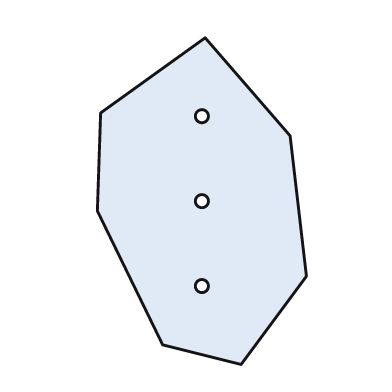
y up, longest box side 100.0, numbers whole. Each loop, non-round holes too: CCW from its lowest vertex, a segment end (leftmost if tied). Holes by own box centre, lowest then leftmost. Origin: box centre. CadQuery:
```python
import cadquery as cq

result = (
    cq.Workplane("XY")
    .moveTo(12.0, -50.0)
    .lineTo(32.0, -23.0)
    .lineTo(27.0, 20.0)
    .lineTo(1.0, 50.0)
    .lineTo(-31.0, 27.0)
    .lineTo(-32.0, -3.0)
    .lineTo(-12.0, -44.0)
    .close()
    .moveTo(0.0, -26.0)
    .circle(2.0)
    .moveTo(0.0, 0.0)
    .circle(2.0)
    .moveTo(0.0, 26.0)
    .circle(2.0)
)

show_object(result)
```